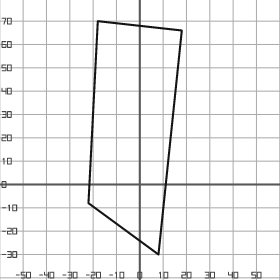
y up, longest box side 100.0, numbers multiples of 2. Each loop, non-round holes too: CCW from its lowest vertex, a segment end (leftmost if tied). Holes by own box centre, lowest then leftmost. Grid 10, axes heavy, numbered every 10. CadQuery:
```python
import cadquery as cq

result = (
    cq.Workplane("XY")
    .moveTo(8.0, -30.0)
    .lineTo(18.0, 66.0)
    .lineTo(-18.0, 70.0)
    .lineTo(-22.0, -8.0)
    .close()
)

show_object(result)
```